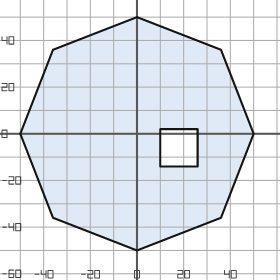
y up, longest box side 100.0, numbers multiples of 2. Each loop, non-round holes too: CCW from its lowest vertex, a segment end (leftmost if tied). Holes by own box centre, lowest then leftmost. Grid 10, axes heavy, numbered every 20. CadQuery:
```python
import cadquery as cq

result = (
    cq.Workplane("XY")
    .moveTo(0.0, -50.0)
    .lineTo(36.0, -36.0)
    .lineTo(50.0, 0.0)
    .lineTo(36.0, 36.0)
    .lineTo(0.0, 50.0)
    .lineTo(-36.0, 36.0)
    .lineTo(-50.0, 0.0)
    .lineTo(-36.0, -36.0)
    .close()
    .moveTo(10.0, -14.0)
    .lineTo(26.0, -14.0)
    .lineTo(26.0, 2.0)
    .lineTo(10.0, 2.0)
    .close()
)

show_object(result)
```